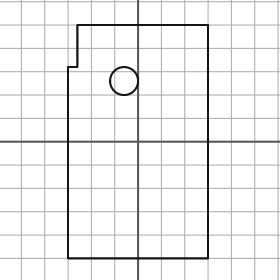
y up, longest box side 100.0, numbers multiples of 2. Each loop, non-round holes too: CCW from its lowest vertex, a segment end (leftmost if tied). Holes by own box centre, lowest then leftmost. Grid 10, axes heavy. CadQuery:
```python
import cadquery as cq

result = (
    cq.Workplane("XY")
    .moveTo(-30.0, -50.0)
    .lineTo(30.0, -50.0)
    .lineTo(30.0, 50.0)
    .lineTo(-26.0, 50.0)
    .lineTo(-26.0, 32.0)
    .lineTo(-30.0, 32.0)
    .close()
    .moveTo(-6.0, 26.0)
    .circle(6.0)
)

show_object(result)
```